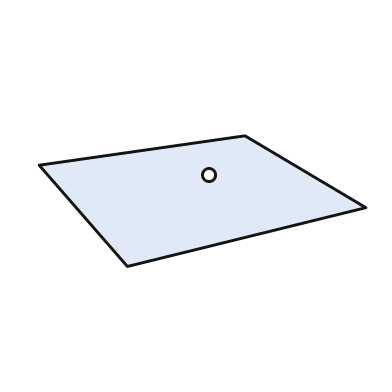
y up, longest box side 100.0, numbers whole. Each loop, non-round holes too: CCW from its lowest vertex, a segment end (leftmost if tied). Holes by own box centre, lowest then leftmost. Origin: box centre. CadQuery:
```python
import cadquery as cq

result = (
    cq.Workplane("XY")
    .moveTo(-23.0, -20.0)
    .lineTo(50.0, -2.0)
    .lineTo(13.0, 20.0)
    .lineTo(-50.0, 11.0)
    .close()
    .moveTo(2.0, 8.0)
    .circle(2.0)
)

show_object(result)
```